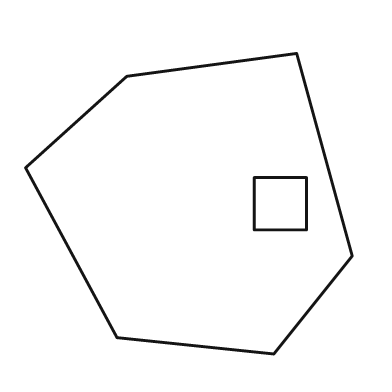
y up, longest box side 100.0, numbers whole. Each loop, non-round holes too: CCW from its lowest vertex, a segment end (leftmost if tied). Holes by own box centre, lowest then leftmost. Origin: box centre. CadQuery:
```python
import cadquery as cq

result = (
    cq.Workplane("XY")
    .moveTo(26.0, -46.0)
    .lineTo(50.0, -16.0)
    .lineTo(33.0, 46.0)
    .lineTo(-19.0, 39.0)
    .lineTo(-50.0, 11.0)
    .lineTo(-22.0, -41.0)
    .close()
    .moveTo(20.0, -8.0)
    .lineTo(36.0, -8.0)
    .lineTo(36.0, 8.0)
    .lineTo(20.0, 8.0)
    .close()
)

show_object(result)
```